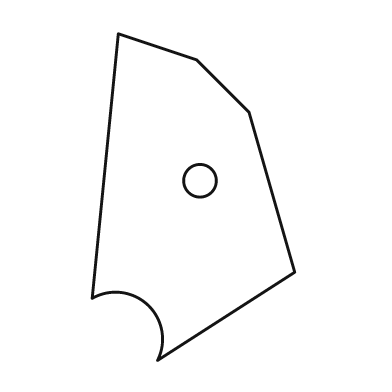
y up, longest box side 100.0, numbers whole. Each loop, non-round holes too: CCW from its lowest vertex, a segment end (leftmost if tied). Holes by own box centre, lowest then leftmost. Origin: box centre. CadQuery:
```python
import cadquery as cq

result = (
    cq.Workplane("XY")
    .moveTo(-11.0, -50.0)
    .lineTo(31.0, -23.0)
    .lineTo(17.0, 26.0)
    .lineTo(1.0, 42.0)
    .lineTo(-23.0, 50.0)
    .lineTo(-31.0, -31.0)
    .threePointArc((-14.0, -33.0), (-11.0, -50.0))
    .close()
    .moveTo(2.0, 5.0)
    .circle(5.0)
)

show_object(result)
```